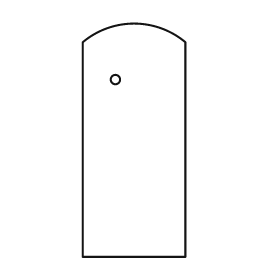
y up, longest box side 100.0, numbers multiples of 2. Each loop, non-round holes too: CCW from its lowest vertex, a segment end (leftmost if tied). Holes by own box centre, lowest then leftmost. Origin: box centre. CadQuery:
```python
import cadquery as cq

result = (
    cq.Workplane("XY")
    .moveTo(-22.0, -50.0)
    .lineTo(22.0, -50.0)
    .lineTo(22.0, 42.0)
    .threePointArc((0.0, 50.0), (-22.0, 42.0))
    .close()
    .moveTo(-8.0, 26.0)
    .circle(2.0)
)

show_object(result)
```